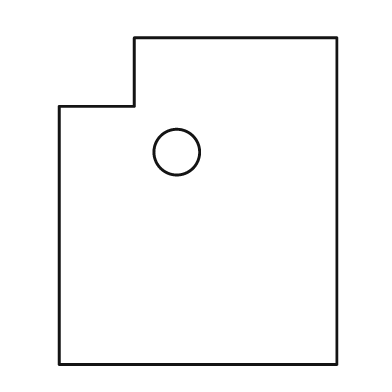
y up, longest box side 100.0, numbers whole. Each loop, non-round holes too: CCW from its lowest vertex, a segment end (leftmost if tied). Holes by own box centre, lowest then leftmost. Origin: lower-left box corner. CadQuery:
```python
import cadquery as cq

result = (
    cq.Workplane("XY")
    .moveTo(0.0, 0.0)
    .lineTo(85.0, 0.0)
    .lineTo(85.0, 100.0)
    .lineTo(23.0, 100.0)
    .lineTo(23.0, 79.0)
    .lineTo(0.0, 79.0)
    .close()
    .moveTo(36.0, 65.0)
    .circle(7.0)
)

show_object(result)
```